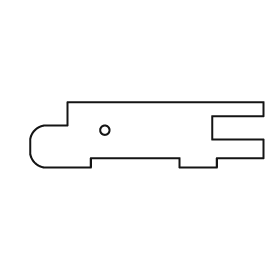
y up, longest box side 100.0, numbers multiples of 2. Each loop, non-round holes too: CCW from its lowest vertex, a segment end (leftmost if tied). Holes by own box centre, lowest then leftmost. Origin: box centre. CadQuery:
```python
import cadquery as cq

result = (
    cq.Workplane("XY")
    .moveTo(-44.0, -14.0)
    .lineTo(-24.0, -14.0)
    .lineTo(-24.0, -10.0)
    .lineTo(14.0, -10.0)
    .lineTo(14.0, -14.0)
    .lineTo(30.0, -14.0)
    .lineTo(30.0, -10.0)
    .lineTo(50.0, -10.0)
    .lineTo(50.0, -2.0)
    .lineTo(28.0, -2.0)
    .lineTo(28.0, 8.0)
    .lineTo(50.0, 8.0)
    .lineTo(50.0, 14.0)
    .lineTo(-34.0, 14.0)
    .lineTo(-34.0, 4.0)
    .lineTo(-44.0, 4.0)
    .threePointArc((-48.0, 2.0), (-50.0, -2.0))
    .lineTo(-50.0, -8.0)
    .threePointArc((-48.0, -12.0), (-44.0, -14.0))
    .close()
    .moveTo(-18.0, 2.0)
    .circle(2.0)
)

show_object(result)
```